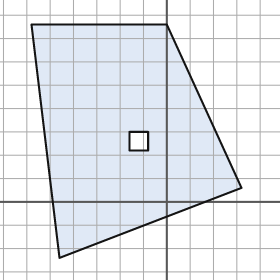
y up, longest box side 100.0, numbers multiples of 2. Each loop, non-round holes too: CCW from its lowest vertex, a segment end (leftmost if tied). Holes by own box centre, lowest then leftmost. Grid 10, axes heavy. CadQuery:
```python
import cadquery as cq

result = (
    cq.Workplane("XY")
    .moveTo(-46.0, -24.0)
    .lineTo(32.0, 6.0)
    .lineTo(0.0, 76.0)
    .lineTo(-58.0, 76.0)
    .close()
    .moveTo(-16.0, 22.0)
    .lineTo(-8.0, 22.0)
    .lineTo(-8.0, 30.0)
    .lineTo(-16.0, 30.0)
    .close()
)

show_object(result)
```